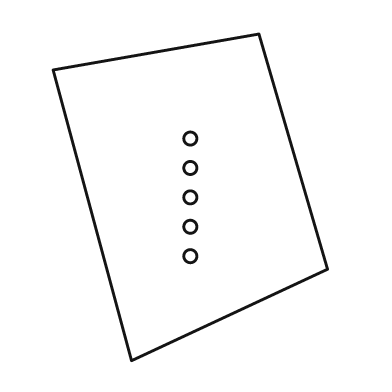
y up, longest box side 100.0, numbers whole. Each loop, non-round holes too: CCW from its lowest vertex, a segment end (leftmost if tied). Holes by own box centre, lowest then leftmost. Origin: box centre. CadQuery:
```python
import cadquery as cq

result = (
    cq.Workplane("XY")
    .moveTo(-18.0, -50.0)
    .lineTo(42.0, -22.0)
    .lineTo(21.0, 50.0)
    .lineTo(-42.0, 39.0)
    .close()
    .moveTo(0.0, -18.0)
    .circle(2.0)
    .moveTo(0.0, -9.0)
    .circle(2.0)
    .moveTo(0.0, 0.0)
    .circle(2.0)
    .moveTo(0.0, 9.0)
    .circle(2.0)
    .moveTo(0.0, 18.0)
    .circle(2.0)
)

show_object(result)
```